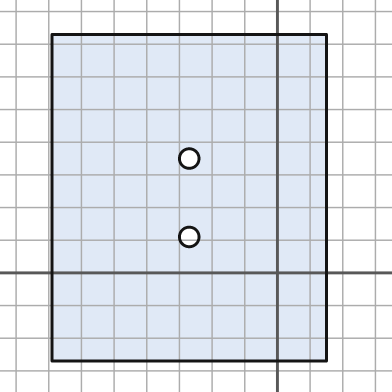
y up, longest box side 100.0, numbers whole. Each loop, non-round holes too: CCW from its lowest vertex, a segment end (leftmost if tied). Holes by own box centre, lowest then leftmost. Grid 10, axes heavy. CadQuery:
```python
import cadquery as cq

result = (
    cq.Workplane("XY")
    .moveTo(-69.0, -27.0)
    .lineTo(15.0, -27.0)
    .lineTo(15.0, 73.0)
    .lineTo(-69.0, 73.0)
    .close()
    .moveTo(-27.0, 11.0)
    .circle(3.0)
    .moveTo(-27.0, 35.0)
    .circle(3.0)
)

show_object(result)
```